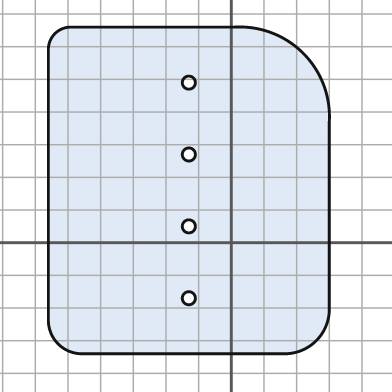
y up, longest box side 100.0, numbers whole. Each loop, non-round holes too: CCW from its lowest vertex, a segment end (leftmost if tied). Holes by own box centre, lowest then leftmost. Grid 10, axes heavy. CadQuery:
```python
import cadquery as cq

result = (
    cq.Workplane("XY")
    .moveTo(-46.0, -34.0)
    .lineTo(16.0, -34.0)
    .threePointArc((26.0, -30.0), (30.0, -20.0))
    .lineTo(30.0, 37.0)
    .threePointArc((22.0, 58.0), (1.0, 66.0))
    .lineTo(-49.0, 66.0)
    .threePointArc((-54.0, 64.0), (-56.0, 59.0))
    .lineTo(-56.0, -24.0)
    .threePointArc((-53.0, -31.0), (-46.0, -34.0))
    .close()
    .moveTo(-13.0, -17.0)
    .circle(2.0)
    .moveTo(-13.0, 5.0)
    .circle(2.0)
    .moveTo(-13.0, 27.0)
    .circle(2.0)
    .moveTo(-13.0, 49.0)
    .circle(2.0)
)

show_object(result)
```